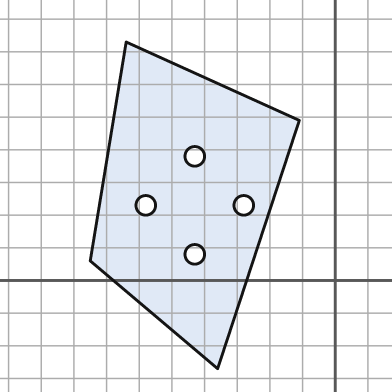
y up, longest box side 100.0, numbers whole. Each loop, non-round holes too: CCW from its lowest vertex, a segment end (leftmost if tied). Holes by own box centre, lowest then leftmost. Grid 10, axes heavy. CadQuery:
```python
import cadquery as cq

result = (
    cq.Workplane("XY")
    .moveTo(-36.0, -27.0)
    .lineTo(-11.0, 49.0)
    .lineTo(-64.0, 73.0)
    .lineTo(-75.0, 6.0)
    .close()
    .moveTo(-43.0, 8.0)
    .circle(3.0)
    .moveTo(-58.0, 23.0)
    .circle(3.0)
    .moveTo(-28.0, 23.0)
    .circle(3.0)
    .moveTo(-43.0, 38.0)
    .circle(3.0)
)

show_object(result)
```